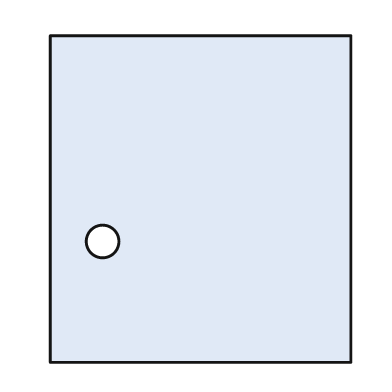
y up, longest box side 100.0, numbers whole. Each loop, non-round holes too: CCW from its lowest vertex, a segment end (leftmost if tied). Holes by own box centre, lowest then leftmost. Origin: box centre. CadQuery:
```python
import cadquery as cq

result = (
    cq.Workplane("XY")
    .moveTo(-46.0, -50.0)
    .lineTo(46.0, -50.0)
    .lineTo(46.0, 50.0)
    .lineTo(-46.0, 50.0)
    .close()
    .moveTo(-30.0, -13.0)
    .circle(5.0)
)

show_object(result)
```